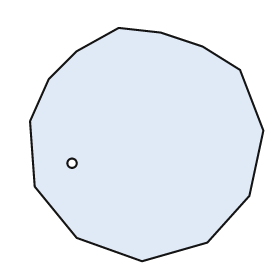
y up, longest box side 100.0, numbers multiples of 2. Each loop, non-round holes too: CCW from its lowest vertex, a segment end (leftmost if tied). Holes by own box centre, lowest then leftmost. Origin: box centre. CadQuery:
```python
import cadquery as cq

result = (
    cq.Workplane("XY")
    .moveTo(-2.0, -50.0)
    .lineTo(26.0, -42.0)
    .lineTo(44.0, -22.0)
    .lineTo(50.0, 6.0)
    .lineTo(40.0, 32.0)
    .lineTo(24.0, 42.0)
    .lineTo(6.0, 48.0)
    .lineTo(-12.0, 50.0)
    .lineTo(-30.0, 40.0)
    .lineTo(-42.0, 28.0)
    .lineTo(-50.0, 10.0)
    .lineTo(-48.0, -18.0)
    .lineTo(-30.0, -40.0)
    .close()
    .moveTo(-32.0, -8.0)
    .circle(2.0)
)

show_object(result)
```